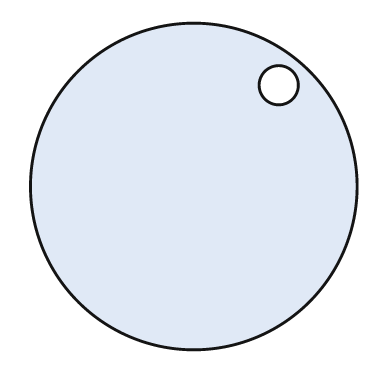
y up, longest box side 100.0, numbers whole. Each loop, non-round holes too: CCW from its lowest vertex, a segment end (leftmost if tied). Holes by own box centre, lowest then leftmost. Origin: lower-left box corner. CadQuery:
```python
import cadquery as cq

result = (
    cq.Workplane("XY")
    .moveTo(50.0, 50.0)
    .circle(50.0)
    .moveTo(76.0, 81.0)
    .circle(6.0)
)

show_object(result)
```